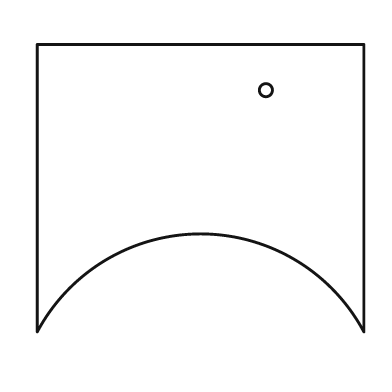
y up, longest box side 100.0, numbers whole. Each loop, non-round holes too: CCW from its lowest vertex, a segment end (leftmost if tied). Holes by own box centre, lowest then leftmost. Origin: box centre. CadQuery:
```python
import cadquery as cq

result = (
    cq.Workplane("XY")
    .moveTo(-50.0, -44.0)
    .threePointArc((0.0, -14.0), (50.0, -44.0))
    .lineTo(50.0, 44.0)
    .lineTo(-50.0, 44.0)
    .close()
    .moveTo(20.0, 30.0)
    .circle(2.0)
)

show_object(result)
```